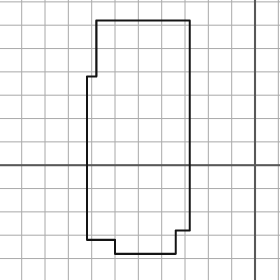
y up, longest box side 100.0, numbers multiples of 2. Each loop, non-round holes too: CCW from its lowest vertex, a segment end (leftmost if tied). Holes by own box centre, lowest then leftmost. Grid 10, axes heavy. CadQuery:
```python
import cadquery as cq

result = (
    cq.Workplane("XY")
    .moveTo(-60.0, -38.0)
    .lineTo(-34.0, -38.0)
    .lineTo(-34.0, -28.0)
    .lineTo(-28.0, -28.0)
    .lineTo(-28.0, 62.0)
    .lineTo(-68.0, 62.0)
    .lineTo(-68.0, 38.0)
    .lineTo(-72.0, 38.0)
    .lineTo(-72.0, -32.0)
    .lineTo(-60.0, -32.0)
    .close()
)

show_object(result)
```